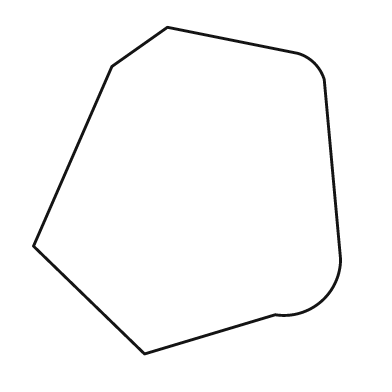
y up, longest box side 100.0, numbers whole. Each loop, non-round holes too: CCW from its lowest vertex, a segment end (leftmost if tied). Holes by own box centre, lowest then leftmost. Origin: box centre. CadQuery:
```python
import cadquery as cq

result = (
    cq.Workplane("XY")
    .moveTo(-13.0, -50.0)
    .lineTo(27.0, -38.0)
    .threePointArc((41.0, -34.0), (47.0, -21.0))
    .lineTo(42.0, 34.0)
    .threePointArc((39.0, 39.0), (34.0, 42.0))
    .lineTo(-6.0, 50.0)
    .lineTo(-23.0, 38.0)
    .lineTo(-47.0, -17.0)
    .close()
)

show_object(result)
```